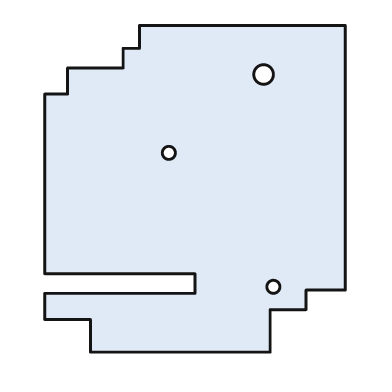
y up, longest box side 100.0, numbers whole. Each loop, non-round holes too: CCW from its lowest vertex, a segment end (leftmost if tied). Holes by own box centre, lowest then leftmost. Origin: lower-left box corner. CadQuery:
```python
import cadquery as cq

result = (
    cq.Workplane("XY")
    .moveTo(14.0, 0.0)
    .lineTo(69.0, 0.0)
    .lineTo(69.0, 13.0)
    .lineTo(80.0, 13.0)
    .lineTo(80.0, 19.0)
    .lineTo(92.0, 19.0)
    .lineTo(92.0, 100.0)
    .lineTo(29.0, 100.0)
    .lineTo(29.0, 93.0)
    .lineTo(24.0, 93.0)
    .lineTo(24.0, 87.0)
    .lineTo(7.0, 87.0)
    .lineTo(7.0, 79.0)
    .lineTo(0.0, 79.0)
    .lineTo(0.0, 24.0)
    .lineTo(46.0, 24.0)
    .lineTo(46.0, 18.0)
    .lineTo(0.0, 18.0)
    .lineTo(0.0, 10.0)
    .lineTo(14.0, 10.0)
    .close()
    .moveTo(70.0, 20.0)
    .circle(2.0)
    .moveTo(38.0, 61.0)
    .circle(2.0)
    .moveTo(67.0, 85.0)
    .circle(3.0)
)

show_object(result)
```